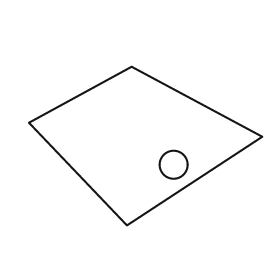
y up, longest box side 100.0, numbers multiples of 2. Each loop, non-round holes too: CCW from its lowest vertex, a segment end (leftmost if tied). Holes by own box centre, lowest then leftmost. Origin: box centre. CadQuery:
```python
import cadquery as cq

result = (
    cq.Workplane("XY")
    .moveTo(-8.0, -34.0)
    .lineTo(50.0, 4.0)
    .lineTo(-6.0, 34.0)
    .lineTo(-50.0, 10.0)
    .close()
    .moveTo(12.0, -8.0)
    .circle(6.0)
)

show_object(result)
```